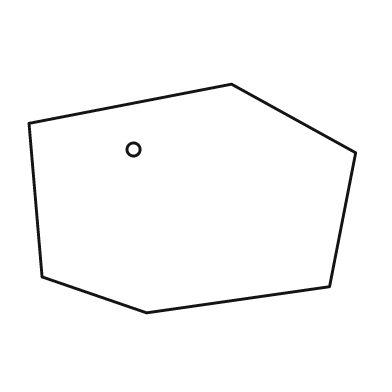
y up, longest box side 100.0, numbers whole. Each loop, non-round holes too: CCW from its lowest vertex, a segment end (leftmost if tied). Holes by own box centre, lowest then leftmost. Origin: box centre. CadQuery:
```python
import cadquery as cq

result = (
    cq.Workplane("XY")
    .moveTo(-14.0, -35.0)
    .lineTo(42.0, -27.0)
    .lineTo(50.0, 14.0)
    .lineTo(12.0, 35.0)
    .lineTo(-50.0, 23.0)
    .lineTo(-46.0, -24.0)
    .close()
    .moveTo(-18.0, 15.0)
    .circle(2.0)
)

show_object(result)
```